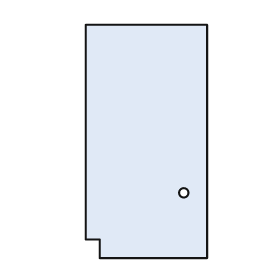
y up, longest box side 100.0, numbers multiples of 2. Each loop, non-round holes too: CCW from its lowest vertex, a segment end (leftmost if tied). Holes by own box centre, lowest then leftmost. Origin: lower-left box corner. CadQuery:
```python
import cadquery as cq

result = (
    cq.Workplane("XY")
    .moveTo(6.0, 0.0)
    .lineTo(52.0, 0.0)
    .lineTo(52.0, 100.0)
    .lineTo(0.0, 100.0)
    .lineTo(0.0, 8.0)
    .lineTo(6.0, 8.0)
    .close()
    .moveTo(42.0, 28.0)
    .circle(2.0)
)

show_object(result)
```